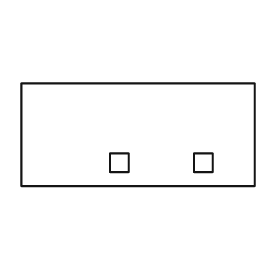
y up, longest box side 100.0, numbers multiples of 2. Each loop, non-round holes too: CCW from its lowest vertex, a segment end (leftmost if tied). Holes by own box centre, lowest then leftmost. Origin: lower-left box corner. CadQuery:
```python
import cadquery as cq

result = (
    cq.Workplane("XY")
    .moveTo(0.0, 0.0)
    .lineTo(100.0, 0.0)
    .lineTo(100.0, 44.0)
    .lineTo(0.0, 44.0)
    .close()
    .moveTo(38.0, 6.0)
    .lineTo(46.0, 6.0)
    .lineTo(46.0, 14.0)
    .lineTo(38.0, 14.0)
    .close()
    .moveTo(74.0, 6.0)
    .lineTo(82.0, 6.0)
    .lineTo(82.0, 14.0)
    .lineTo(74.0, 14.0)
    .close()
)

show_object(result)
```